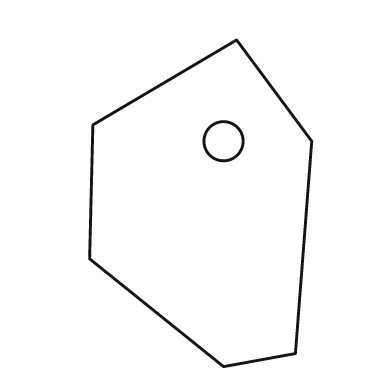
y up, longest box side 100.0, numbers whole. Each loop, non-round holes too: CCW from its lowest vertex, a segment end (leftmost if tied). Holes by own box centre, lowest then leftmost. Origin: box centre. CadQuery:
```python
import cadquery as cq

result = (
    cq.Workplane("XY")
    .moveTo(7.0, -50.0)
    .lineTo(29.0, -46.0)
    .lineTo(34.0, 19.0)
    .lineTo(11.0, 50.0)
    .lineTo(-33.0, 24.0)
    .lineTo(-34.0, -17.0)
    .close()
    .moveTo(7.0, 19.0)
    .circle(6.0)
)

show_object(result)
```